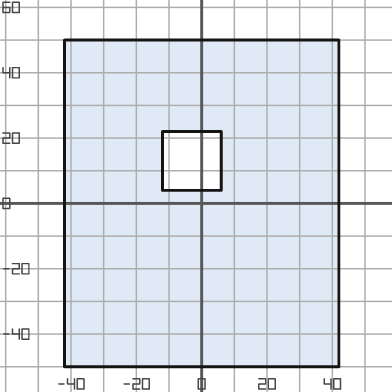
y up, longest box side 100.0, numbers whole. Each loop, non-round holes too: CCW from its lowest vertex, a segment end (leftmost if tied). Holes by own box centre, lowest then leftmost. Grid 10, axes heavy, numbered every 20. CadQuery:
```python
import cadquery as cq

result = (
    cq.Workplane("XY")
    .moveTo(-42.0, -50.0)
    .lineTo(42.0, -50.0)
    .lineTo(42.0, 50.0)
    .lineTo(-42.0, 50.0)
    .close()
    .moveTo(-12.0, 4.0)
    .lineTo(6.0, 4.0)
    .lineTo(6.0, 22.0)
    .lineTo(-12.0, 22.0)
    .close()
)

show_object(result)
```